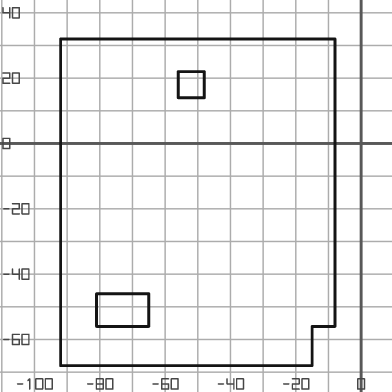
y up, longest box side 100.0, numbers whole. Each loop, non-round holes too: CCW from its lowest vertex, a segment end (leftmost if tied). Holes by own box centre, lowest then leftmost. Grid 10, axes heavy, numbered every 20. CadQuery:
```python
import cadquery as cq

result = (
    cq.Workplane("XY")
    .moveTo(-92.0, -68.0)
    .lineTo(-15.0, -68.0)
    .lineTo(-15.0, -56.0)
    .lineTo(-8.0, -56.0)
    .lineTo(-8.0, 32.0)
    .lineTo(-92.0, 32.0)
    .close()
    .moveTo(-81.0, -56.0)
    .lineTo(-65.0, -56.0)
    .lineTo(-65.0, -46.0)
    .lineTo(-81.0, -46.0)
    .close()
    .moveTo(-56.0, 14.0)
    .lineTo(-48.0, 14.0)
    .lineTo(-48.0, 22.0)
    .lineTo(-56.0, 22.0)
    .close()
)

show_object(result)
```